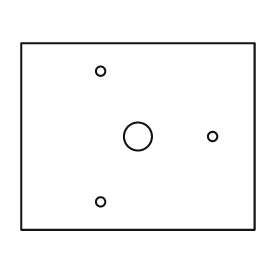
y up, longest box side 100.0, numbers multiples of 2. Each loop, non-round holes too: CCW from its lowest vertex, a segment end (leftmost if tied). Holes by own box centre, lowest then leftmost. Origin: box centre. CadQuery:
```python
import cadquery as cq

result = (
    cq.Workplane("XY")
    .moveTo(-50.0, -40.0)
    .lineTo(50.0, -40.0)
    .lineTo(50.0, 40.0)
    .lineTo(-50.0, 40.0)
    .close()
    .moveTo(-16.0, -28.0)
    .circle(2.0)
    .moveTo(0.0, 0.0)
    .circle(6.0)
    .moveTo(32.0, 0.0)
    .circle(2.0)
    .moveTo(-16.0, 28.0)
    .circle(2.0)
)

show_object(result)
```